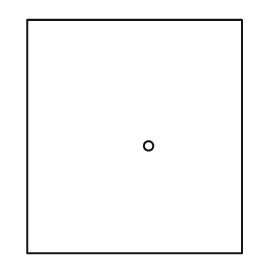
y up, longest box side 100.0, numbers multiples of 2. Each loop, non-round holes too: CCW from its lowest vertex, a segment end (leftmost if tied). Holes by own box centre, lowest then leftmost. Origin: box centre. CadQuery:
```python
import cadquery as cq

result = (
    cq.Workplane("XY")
    .moveTo(-46.0, -50.0)
    .lineTo(46.0, -50.0)
    .lineTo(46.0, 50.0)
    .lineTo(-46.0, 50.0)
    .close()
    .moveTo(6.0, -4.0)
    .circle(2.0)
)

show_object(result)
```